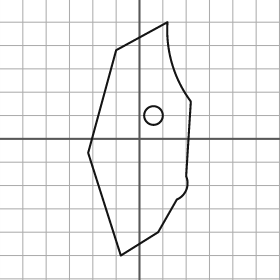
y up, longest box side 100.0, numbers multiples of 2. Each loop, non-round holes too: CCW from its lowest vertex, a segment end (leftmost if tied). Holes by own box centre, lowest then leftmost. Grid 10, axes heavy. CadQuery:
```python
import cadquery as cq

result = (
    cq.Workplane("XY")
    .moveTo(-8.0, -50.0)
    .lineTo(8.0, -40.0)
    .lineTo(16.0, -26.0)
    .threePointArc((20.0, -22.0), (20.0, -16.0))
    .lineTo(22.0, 16.0)
    .threePointArc((14.0, 32.0), (12.0, 50.0))
    .lineTo(-10.0, 38.0)
    .lineTo(-22.0, -6.0)
    .close()
    .moveTo(6.0, 10.0)
    .circle(4.0)
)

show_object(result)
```